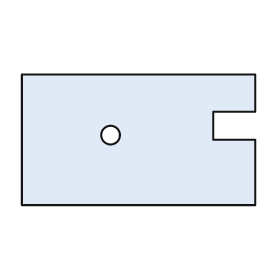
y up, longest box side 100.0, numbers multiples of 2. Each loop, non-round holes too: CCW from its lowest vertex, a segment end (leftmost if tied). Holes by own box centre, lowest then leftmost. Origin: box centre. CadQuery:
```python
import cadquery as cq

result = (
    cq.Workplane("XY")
    .moveTo(-50.0, -28.0)
    .lineTo(50.0, -28.0)
    .lineTo(50.0, 0.0)
    .lineTo(32.0, 0.0)
    .lineTo(32.0, 12.0)
    .lineTo(50.0, 12.0)
    .lineTo(50.0, 28.0)
    .lineTo(-50.0, 28.0)
    .close()
    .moveTo(-12.0, 2.0)
    .circle(4.0)
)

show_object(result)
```